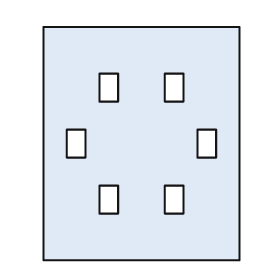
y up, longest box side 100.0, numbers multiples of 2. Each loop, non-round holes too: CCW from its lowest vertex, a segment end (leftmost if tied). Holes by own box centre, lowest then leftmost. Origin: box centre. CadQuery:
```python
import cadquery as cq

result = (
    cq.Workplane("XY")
    .moveTo(-42.0, -50.0)
    .lineTo(42.0, -50.0)
    .lineTo(42.0, 50.0)
    .lineTo(-42.0, 50.0)
    .close()
    .moveTo(-18.0, -30.0)
    .lineTo(-10.0, -30.0)
    .lineTo(-10.0, -18.0)
    .lineTo(-18.0, -18.0)
    .close()
    .moveTo(10.0, -30.0)
    .lineTo(18.0, -30.0)
    .lineTo(18.0, -18.0)
    .lineTo(10.0, -18.0)
    .close()
    .moveTo(-32.0, -6.0)
    .lineTo(-24.0, -6.0)
    .lineTo(-24.0, 6.0)
    .lineTo(-32.0, 6.0)
    .close()
    .moveTo(24.0, -6.0)
    .lineTo(32.0, -6.0)
    .lineTo(32.0, 6.0)
    .lineTo(24.0, 6.0)
    .close()
    .moveTo(-18.0, 18.0)
    .lineTo(-10.0, 18.0)
    .lineTo(-10.0, 30.0)
    .lineTo(-18.0, 30.0)
    .close()
    .moveTo(10.0, 18.0)
    .lineTo(18.0, 18.0)
    .lineTo(18.0, 30.0)
    .lineTo(10.0, 30.0)
    .close()
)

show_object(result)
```